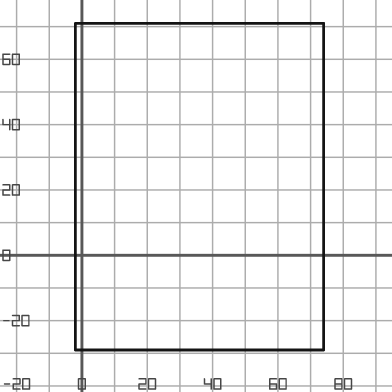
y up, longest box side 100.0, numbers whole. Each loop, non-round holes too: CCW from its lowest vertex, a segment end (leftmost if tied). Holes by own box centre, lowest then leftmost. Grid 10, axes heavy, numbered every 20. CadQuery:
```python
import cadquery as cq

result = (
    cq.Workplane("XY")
    .moveTo(-2.0, -29.0)
    .lineTo(74.0, -29.0)
    .lineTo(74.0, 71.0)
    .lineTo(-2.0, 71.0)
    .close()
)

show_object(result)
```